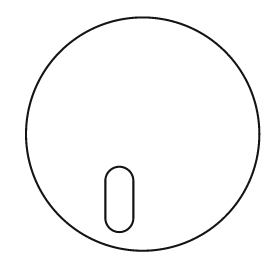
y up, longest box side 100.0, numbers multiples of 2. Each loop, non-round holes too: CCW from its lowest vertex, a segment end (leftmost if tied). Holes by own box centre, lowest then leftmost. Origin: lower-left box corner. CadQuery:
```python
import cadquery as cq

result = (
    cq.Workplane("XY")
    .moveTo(50.0, 50.0)
    .circle(50.0)
    .moveTo(34.0, 14.0)
    .threePointArc((40.0, 8.0), (46.0, 14.0))
    .lineTo(46.0, 30.0)
    .threePointArc((40.0, 36.0), (34.0, 30.0))
    .close()
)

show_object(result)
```